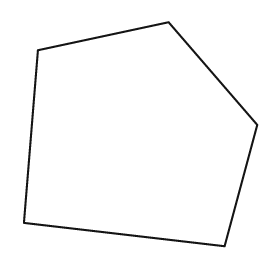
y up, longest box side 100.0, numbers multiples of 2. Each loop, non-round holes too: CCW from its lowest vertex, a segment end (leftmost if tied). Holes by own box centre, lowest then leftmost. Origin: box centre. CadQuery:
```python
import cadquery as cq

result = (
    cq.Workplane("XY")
    .moveTo(36.0, -48.0)
    .lineTo(50.0, 4.0)
    .lineTo(12.0, 48.0)
    .lineTo(-44.0, 36.0)
    .lineTo(-50.0, -38.0)
    .close()
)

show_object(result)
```